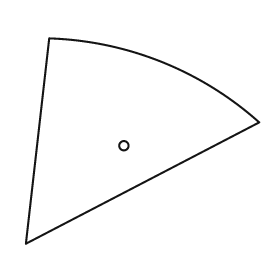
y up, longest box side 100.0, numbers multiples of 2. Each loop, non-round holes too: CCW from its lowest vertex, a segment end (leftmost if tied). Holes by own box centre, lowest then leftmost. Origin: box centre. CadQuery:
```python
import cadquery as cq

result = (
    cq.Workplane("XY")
    .moveTo(-50.0, -44.0)
    .lineTo(50.0, 8.0)
    .threePointArc((8.0, 34.0), (-40.0, 44.0))
    .close()
    .moveTo(-8.0, -2.0)
    .circle(2.0)
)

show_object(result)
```